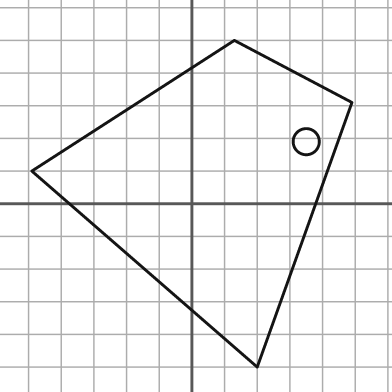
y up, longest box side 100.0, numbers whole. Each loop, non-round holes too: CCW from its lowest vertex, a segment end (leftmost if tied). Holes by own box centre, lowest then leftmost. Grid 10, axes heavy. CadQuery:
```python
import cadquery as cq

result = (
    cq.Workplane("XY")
    .moveTo(20.0, -50.0)
    .lineTo(49.0, 31.0)
    .lineTo(13.0, 50.0)
    .lineTo(-49.0, 10.0)
    .close()
    .moveTo(35.0, 19.0)
    .circle(4.0)
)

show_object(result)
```